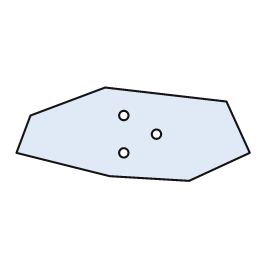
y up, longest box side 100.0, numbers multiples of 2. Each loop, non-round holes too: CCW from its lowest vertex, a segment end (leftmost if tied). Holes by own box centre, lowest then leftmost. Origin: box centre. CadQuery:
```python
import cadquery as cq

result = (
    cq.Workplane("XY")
    .moveTo(24.0, -20.0)
    .lineTo(50.0, -8.0)
    .lineTo(40.0, 14.0)
    .lineTo(-12.0, 20.0)
    .lineTo(-44.0, 8.0)
    .lineTo(-50.0, -8.0)
    .lineTo(-10.0, -18.0)
    .close()
    .moveTo(-4.0, -8.0)
    .circle(2.0)
    .moveTo(10.0, 0.0)
    .circle(2.0)
    .moveTo(-4.0, 8.0)
    .circle(2.0)
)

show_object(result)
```